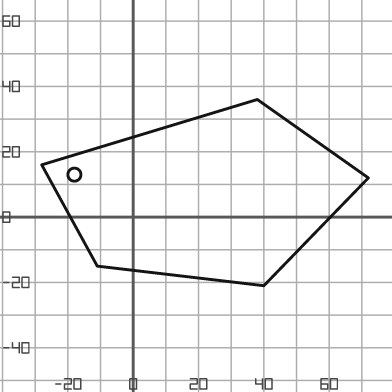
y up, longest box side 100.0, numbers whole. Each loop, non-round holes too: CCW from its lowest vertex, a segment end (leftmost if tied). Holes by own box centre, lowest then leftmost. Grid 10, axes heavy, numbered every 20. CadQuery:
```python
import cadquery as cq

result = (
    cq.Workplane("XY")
    .moveTo(40.0, -21.0)
    .lineTo(72.0, 12.0)
    .lineTo(38.0, 36.0)
    .lineTo(-28.0, 16.0)
    .lineTo(-11.0, -15.0)
    .close()
    .moveTo(-18.0, 13.0)
    .circle(2.0)
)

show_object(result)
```